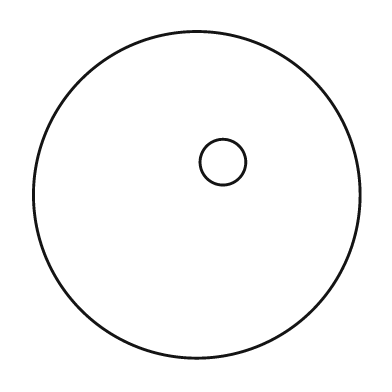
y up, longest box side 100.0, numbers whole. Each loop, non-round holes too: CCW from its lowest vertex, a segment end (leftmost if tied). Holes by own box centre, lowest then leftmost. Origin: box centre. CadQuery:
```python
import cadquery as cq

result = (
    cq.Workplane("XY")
    .moveTo(0.0, 0.0)
    .circle(50.0)
    .moveTo(8.0, 10.0)
    .circle(7.0)
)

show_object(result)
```